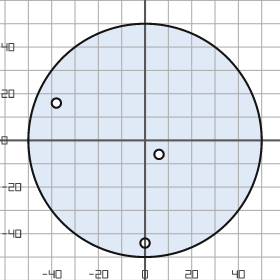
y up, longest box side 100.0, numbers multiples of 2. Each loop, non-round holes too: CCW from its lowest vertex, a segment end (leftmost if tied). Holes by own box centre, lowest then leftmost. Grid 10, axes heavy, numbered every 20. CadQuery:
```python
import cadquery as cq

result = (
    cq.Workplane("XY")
    .moveTo(0.0, 0.0)
    .circle(50.0)
    .moveTo(0.0, -44.0)
    .circle(2.0)
    .moveTo(6.0, -6.0)
    .circle(2.0)
    .moveTo(-38.0, 16.0)
    .circle(2.0)
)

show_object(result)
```